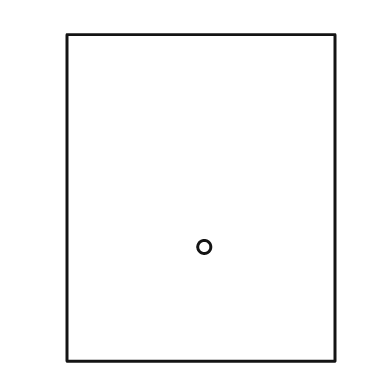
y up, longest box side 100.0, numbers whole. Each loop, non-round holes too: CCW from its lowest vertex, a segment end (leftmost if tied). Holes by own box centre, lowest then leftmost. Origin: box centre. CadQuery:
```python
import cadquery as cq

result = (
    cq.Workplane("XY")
    .moveTo(-41.0, -50.0)
    .lineTo(41.0, -50.0)
    .lineTo(41.0, 50.0)
    .lineTo(-41.0, 50.0)
    .close()
    .moveTo(1.0, -15.0)
    .circle(2.0)
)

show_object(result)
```